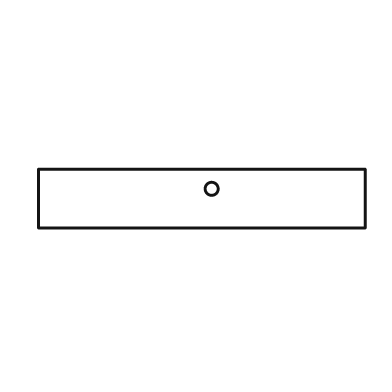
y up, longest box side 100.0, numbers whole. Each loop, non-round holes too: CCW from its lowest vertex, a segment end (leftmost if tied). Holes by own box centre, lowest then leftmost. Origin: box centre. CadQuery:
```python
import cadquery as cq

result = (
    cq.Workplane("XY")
    .moveTo(-50.0, -9.0)
    .lineTo(50.0, -9.0)
    .lineTo(50.0, 9.0)
    .lineTo(-50.0, 9.0)
    .close()
    .moveTo(3.0, 3.0)
    .circle(2.0)
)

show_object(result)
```